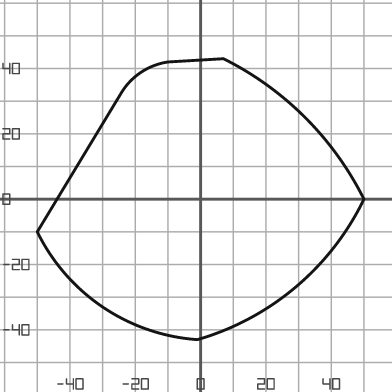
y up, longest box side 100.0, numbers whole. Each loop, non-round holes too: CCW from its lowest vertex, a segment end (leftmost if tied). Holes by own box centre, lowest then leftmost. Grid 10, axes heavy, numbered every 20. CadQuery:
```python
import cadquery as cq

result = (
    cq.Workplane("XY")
    .moveTo(-1.0, -43.0)
    .threePointArc((29.0, -27.0), (50.0, 0.0))
    .threePointArc((32.0, 25.0), (7.0, 43.0))
    .lineTo(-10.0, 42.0)
    .threePointArc((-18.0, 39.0), (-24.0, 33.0))
    .lineTo(-50.0, -10.0)
    .threePointArc((-30.0, -33.0), (-1.0, -43.0))
    .close()
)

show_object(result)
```